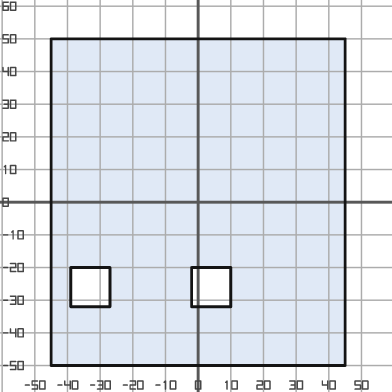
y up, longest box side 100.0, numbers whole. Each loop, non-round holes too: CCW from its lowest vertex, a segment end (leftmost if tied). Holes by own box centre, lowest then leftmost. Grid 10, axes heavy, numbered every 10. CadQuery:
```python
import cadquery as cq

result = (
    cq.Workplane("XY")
    .moveTo(-45.0, -50.0)
    .lineTo(45.0, -50.0)
    .lineTo(45.0, 50.0)
    .lineTo(-45.0, 50.0)
    .close()
    .moveTo(-39.0, -32.0)
    .lineTo(-27.0, -32.0)
    .lineTo(-27.0, -20.0)
    .lineTo(-39.0, -20.0)
    .close()
    .moveTo(-2.0, -32.0)
    .lineTo(10.0, -32.0)
    .lineTo(10.0, -20.0)
    .lineTo(-2.0, -20.0)
    .close()
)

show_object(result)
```